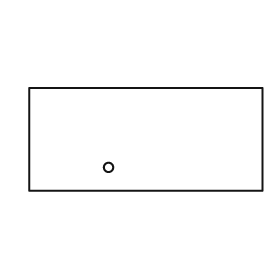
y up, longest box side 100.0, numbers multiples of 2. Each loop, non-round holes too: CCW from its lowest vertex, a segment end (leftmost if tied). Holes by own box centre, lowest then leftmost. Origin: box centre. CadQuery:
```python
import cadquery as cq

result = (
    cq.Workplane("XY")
    .moveTo(-50.0, -22.0)
    .lineTo(50.0, -22.0)
    .lineTo(50.0, 22.0)
    .lineTo(-50.0, 22.0)
    .close()
    .moveTo(-16.0, -12.0)
    .circle(2.0)
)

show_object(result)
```